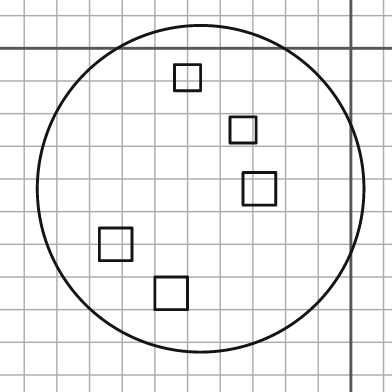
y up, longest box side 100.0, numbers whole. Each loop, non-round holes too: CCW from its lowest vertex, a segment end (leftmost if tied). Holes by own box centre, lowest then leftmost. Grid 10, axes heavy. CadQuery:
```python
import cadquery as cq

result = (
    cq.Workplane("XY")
    .moveTo(-46.0, -43.0)
    .circle(50.0)
    .moveTo(-60.0, -80.0)
    .lineTo(-50.0, -80.0)
    .lineTo(-50.0, -70.0)
    .lineTo(-60.0, -70.0)
    .close()
    .moveTo(-77.0, -65.0)
    .lineTo(-67.0, -65.0)
    .lineTo(-67.0, -55.0)
    .lineTo(-77.0, -55.0)
    .close()
    .moveTo(-33.0, -48.0)
    .lineTo(-23.0, -48.0)
    .lineTo(-23.0, -38.0)
    .lineTo(-33.0, -38.0)
    .close()
    .moveTo(-37.0, -29.0)
    .lineTo(-29.0, -29.0)
    .lineTo(-29.0, -21.0)
    .lineTo(-37.0, -21.0)
    .close()
    .moveTo(-54.0, -13.0)
    .lineTo(-46.0, -13.0)
    .lineTo(-46.0, -5.0)
    .lineTo(-54.0, -5.0)
    .close()
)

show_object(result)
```